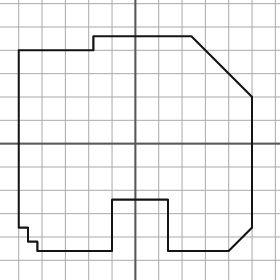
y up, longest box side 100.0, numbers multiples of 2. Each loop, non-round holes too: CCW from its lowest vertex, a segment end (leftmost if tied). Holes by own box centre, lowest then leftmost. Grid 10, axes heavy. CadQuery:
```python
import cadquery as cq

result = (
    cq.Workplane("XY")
    .moveTo(-42.0, -46.0)
    .lineTo(-10.0, -46.0)
    .lineTo(-10.0, -24.0)
    .lineTo(14.0, -24.0)
    .lineTo(14.0, -46.0)
    .lineTo(40.0, -46.0)
    .lineTo(50.0, -36.0)
    .lineTo(50.0, 20.0)
    .lineTo(24.0, 46.0)
    .lineTo(-18.0, 46.0)
    .lineTo(-18.0, 40.0)
    .lineTo(-50.0, 40.0)
    .lineTo(-50.0, -36.0)
    .lineTo(-46.0, -36.0)
    .lineTo(-46.0, -42.0)
    .lineTo(-42.0, -42.0)
    .close()
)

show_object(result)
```